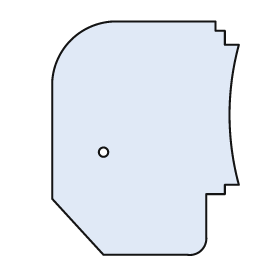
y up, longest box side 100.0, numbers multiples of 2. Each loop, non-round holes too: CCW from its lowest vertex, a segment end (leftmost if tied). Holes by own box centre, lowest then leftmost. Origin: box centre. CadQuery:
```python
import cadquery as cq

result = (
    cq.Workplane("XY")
    .moveTo(-18.0, -50.0)
    .lineTo(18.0, -50.0)
    .threePointArc((24.0, -48.0), (26.0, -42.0))
    .lineTo(26.0, -24.0)
    .lineTo(34.0, -24.0)
    .lineTo(34.0, -20.0)
    .lineTo(40.0, -20.0)
    .threePointArc((36.0, 10.0), (40.0, 40.0))
    .lineTo(34.0, 40.0)
    .lineTo(34.0, 46.0)
    .lineTo(30.0, 46.0)
    .lineTo(30.0, 50.0)
    .lineTo(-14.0, 50.0)
    .threePointArc((-32.0, 42.0), (-40.0, 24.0))
    .lineTo(-40.0, -26.0)
    .close()
    .moveTo(-18.0, -6.0)
    .circle(2.0)
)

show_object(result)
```